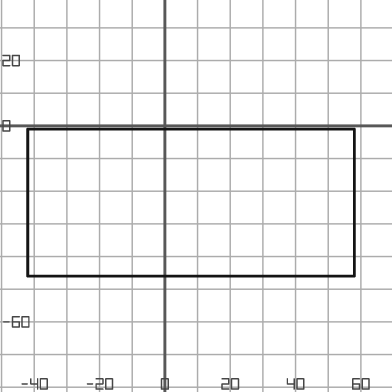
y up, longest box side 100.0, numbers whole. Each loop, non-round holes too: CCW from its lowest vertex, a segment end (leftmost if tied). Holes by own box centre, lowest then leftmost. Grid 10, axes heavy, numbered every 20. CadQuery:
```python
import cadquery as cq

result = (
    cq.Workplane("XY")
    .moveTo(-42.0, -46.0)
    .lineTo(58.0, -46.0)
    .lineTo(58.0, -1.0)
    .lineTo(-42.0, -1.0)
    .close()
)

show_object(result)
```